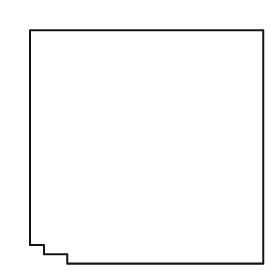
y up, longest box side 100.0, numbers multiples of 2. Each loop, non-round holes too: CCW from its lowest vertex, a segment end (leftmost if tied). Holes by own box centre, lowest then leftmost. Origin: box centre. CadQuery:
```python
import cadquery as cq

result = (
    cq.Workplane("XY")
    .moveTo(-34.0, -50.0)
    .lineTo(50.0, -50.0)
    .lineTo(50.0, 50.0)
    .lineTo(-50.0, 50.0)
    .lineTo(-50.0, -42.0)
    .lineTo(-44.0, -42.0)
    .lineTo(-44.0, -46.0)
    .lineTo(-34.0, -46.0)
    .close()
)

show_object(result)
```